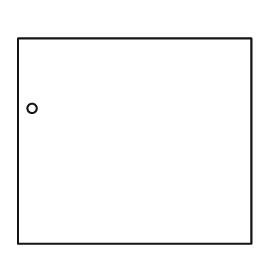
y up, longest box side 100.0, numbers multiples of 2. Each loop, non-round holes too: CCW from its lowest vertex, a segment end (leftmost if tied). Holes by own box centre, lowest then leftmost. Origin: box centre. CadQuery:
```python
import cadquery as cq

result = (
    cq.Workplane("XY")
    .moveTo(-50.0, -44.0)
    .lineTo(50.0, -44.0)
    .lineTo(50.0, 44.0)
    .lineTo(-50.0, 44.0)
    .close()
    .moveTo(-44.0, 14.0)
    .circle(2.0)
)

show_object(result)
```